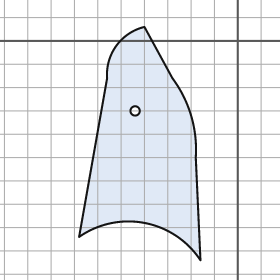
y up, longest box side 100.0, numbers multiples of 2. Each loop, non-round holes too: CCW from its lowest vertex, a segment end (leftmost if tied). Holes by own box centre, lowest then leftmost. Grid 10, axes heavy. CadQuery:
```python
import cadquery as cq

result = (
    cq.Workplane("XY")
    .moveTo(-16.0, -94.0)
    .lineTo(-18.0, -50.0)
    .threePointArc((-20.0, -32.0), (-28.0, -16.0))
    .lineTo(-40.0, 6.0)
    .threePointArc((-52.0, -2.0), (-56.0, -16.0))
    .lineTo(-68.0, -84.0)
    .threePointArc((-40.0, -78.0), (-16.0, -94.0))
    .close()
    .moveTo(-44.0, -30.0)
    .circle(2.0)
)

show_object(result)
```